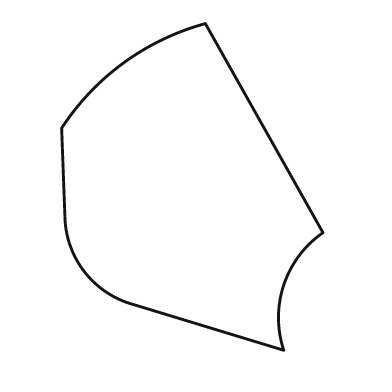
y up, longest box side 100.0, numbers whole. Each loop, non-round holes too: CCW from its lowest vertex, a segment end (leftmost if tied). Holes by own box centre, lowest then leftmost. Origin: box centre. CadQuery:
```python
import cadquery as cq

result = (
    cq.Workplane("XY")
    .moveTo(28.0, -50.0)
    .threePointArc((28.0, -30.0), (40.0, -14.0))
    .lineTo(4.0, 50.0)
    .threePointArc((-21.0, 38.0), (-40.0, 18.0))
    .lineTo(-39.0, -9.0)
    .threePointArc((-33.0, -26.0), (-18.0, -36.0))
    .close()
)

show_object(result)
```